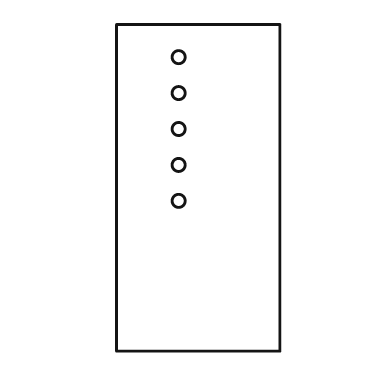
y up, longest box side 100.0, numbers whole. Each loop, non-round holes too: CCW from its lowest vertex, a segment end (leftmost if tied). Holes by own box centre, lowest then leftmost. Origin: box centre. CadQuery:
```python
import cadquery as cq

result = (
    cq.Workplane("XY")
    .moveTo(-25.0, -50.0)
    .lineTo(25.0, -50.0)
    .lineTo(25.0, 50.0)
    .lineTo(-25.0, 50.0)
    .close()
    .moveTo(-6.0, -4.0)
    .circle(2.0)
    .moveTo(-6.0, 7.0)
    .circle(2.0)
    .moveTo(-6.0, 18.0)
    .circle(2.0)
    .moveTo(-6.0, 29.0)
    .circle(2.0)
    .moveTo(-6.0, 40.0)
    .circle(2.0)
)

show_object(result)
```